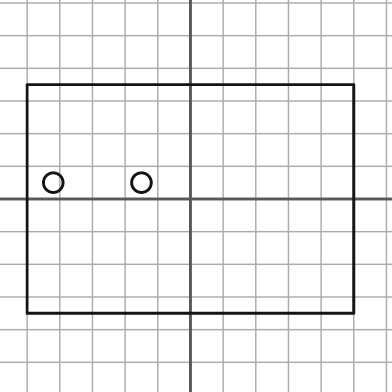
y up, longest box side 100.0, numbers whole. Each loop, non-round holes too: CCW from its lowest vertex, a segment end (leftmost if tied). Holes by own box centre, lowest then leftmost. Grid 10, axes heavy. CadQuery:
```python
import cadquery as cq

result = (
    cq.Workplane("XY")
    .moveTo(-50.0, -35.0)
    .lineTo(50.0, -35.0)
    .lineTo(50.0, 35.0)
    .lineTo(-50.0, 35.0)
    .close()
    .moveTo(-42.0, 5.0)
    .circle(3.0)
    .moveTo(-15.0, 5.0)
    .circle(3.0)
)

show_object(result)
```